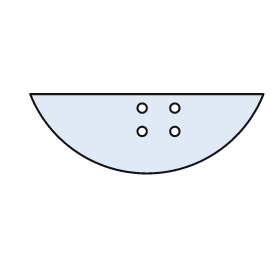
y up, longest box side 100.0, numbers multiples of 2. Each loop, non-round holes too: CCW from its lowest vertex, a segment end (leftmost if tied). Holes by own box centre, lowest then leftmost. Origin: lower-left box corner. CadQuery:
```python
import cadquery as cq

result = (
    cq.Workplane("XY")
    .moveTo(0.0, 34.0)
    .threePointArc((50.0, 0.0), (100.0, 34.0))
    .close()
    .moveTo(48.0, 18.0)
    .circle(2.0)
    .moveTo(62.0, 18.0)
    .circle(2.0)
    .moveTo(48.0, 28.0)
    .circle(2.0)
    .moveTo(62.0, 28.0)
    .circle(2.0)
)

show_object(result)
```